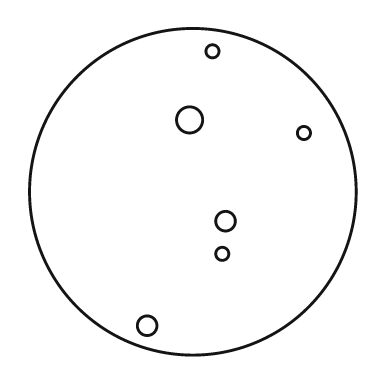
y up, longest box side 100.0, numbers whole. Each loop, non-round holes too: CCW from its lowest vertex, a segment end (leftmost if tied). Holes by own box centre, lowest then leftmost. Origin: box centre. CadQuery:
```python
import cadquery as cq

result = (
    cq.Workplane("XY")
    .moveTo(0.0, 0.0)
    .circle(50.0)
    .moveTo(-14.0, -41.0)
    .circle(3.0)
    .moveTo(9.0, -19.0)
    .circle(2.0)
    .moveTo(10.0, -9.0)
    .circle(3.0)
    .moveTo(34.0, 18.0)
    .circle(2.0)
    .moveTo(-1.0, 22.0)
    .circle(4.0)
    .moveTo(6.0, 43.0)
    .circle(2.0)
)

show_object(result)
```